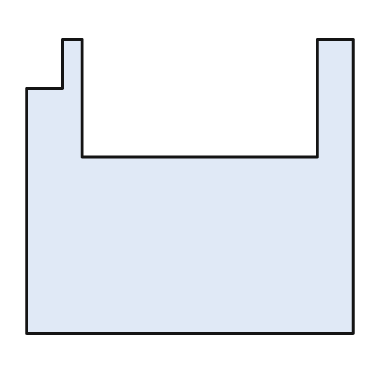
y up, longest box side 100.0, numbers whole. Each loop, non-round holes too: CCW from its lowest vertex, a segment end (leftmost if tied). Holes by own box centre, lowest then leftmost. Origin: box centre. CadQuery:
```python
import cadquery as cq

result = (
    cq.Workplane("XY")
    .moveTo(-50.0, -45.0)
    .lineTo(50.0, -45.0)
    .lineTo(50.0, 45.0)
    .lineTo(39.0, 45.0)
    .lineTo(39.0, 9.0)
    .lineTo(-33.0, 9.0)
    .lineTo(-33.0, 45.0)
    .lineTo(-39.0, 45.0)
    .lineTo(-39.0, 30.0)
    .lineTo(-50.0, 30.0)
    .close()
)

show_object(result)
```